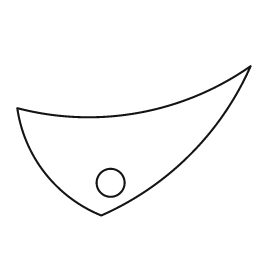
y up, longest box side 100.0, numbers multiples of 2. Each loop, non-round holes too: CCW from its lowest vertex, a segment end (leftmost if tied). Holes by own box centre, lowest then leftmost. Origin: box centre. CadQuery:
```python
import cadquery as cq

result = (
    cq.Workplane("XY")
    .moveTo(-14.0, -32.0)
    .threePointArc((24.0, -6.0), (50.0, 32.0))
    .threePointArc((2.0, 12.0), (-50.0, 14.0))
    .threePointArc((-38.0, -14.0), (-14.0, -32.0))
    .close()
    .moveTo(-10.0, -18.0)
    .circle(6.0)
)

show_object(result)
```